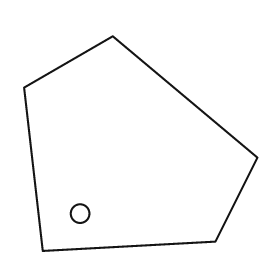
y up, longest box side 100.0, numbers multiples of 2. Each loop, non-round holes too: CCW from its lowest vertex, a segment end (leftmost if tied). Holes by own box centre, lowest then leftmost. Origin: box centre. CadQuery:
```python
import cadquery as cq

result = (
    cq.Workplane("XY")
    .moveTo(-42.0, -46.0)
    .lineTo(32.0, -42.0)
    .lineTo(50.0, -6.0)
    .lineTo(-12.0, 46.0)
    .lineTo(-50.0, 24.0)
    .close()
    .moveTo(-26.0, -30.0)
    .circle(4.0)
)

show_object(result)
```